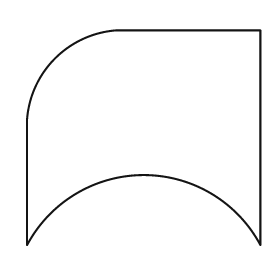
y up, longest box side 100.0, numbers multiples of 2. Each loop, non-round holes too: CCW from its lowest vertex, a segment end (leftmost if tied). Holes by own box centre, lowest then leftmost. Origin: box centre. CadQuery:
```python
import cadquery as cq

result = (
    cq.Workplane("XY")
    .moveTo(-50.0, -46.0)
    .threePointArc((0.0, -16.0), (50.0, -46.0))
    .lineTo(50.0, 46.0)
    .lineTo(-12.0, 46.0)
    .threePointArc((-38.0, 34.0), (-50.0, 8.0))
    .close()
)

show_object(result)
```